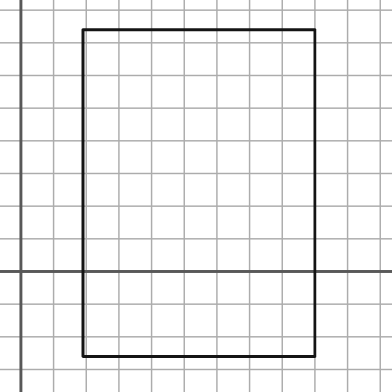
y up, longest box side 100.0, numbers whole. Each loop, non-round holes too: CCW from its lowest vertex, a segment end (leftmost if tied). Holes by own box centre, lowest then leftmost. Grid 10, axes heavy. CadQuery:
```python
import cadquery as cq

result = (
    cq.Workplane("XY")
    .moveTo(19.0, -26.0)
    .lineTo(90.0, -26.0)
    .lineTo(90.0, 74.0)
    .lineTo(19.0, 74.0)
    .close()
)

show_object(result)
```